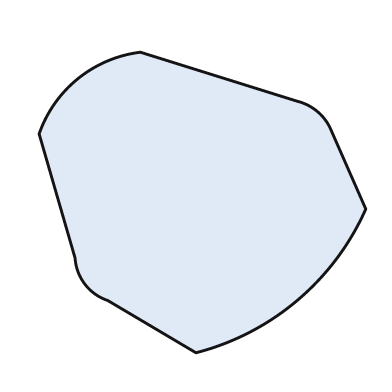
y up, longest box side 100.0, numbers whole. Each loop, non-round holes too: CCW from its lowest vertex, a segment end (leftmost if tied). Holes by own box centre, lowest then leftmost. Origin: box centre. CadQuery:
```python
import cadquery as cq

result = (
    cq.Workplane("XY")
    .moveTo(-2.0, -46.0)
    .threePointArc((29.0, -30.0), (50.0, -2.0))
    .lineTo(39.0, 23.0)
    .threePointArc((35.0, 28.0), (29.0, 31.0))
    .lineTo(-19.0, 46.0)
    .threePointArc((-38.0, 38.0), (-50.0, 21.0))
    .lineTo(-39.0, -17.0)
    .threePointArc((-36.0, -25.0), (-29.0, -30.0))
    .close()
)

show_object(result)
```